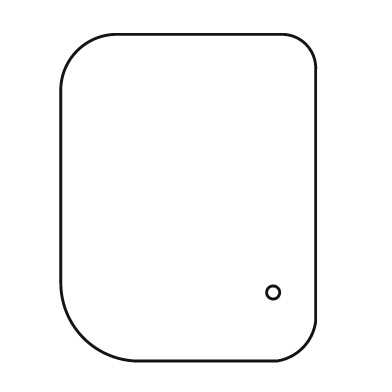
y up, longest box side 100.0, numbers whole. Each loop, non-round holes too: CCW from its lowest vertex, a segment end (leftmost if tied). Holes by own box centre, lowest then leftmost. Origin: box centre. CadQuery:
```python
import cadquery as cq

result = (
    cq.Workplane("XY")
    .moveTo(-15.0, -50.0)
    .lineTo(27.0, -50.0)
    .threePointArc((35.0, -46.0), (39.0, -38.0))
    .lineTo(39.0, 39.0)
    .threePointArc((36.0, 47.0), (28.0, 50.0))
    .lineTo(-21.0, 50.0)
    .threePointArc((-34.0, 45.0), (-39.0, 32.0))
    .lineTo(-39.0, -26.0)
    .threePointArc((-32.0, -43.0), (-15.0, -50.0))
    .close()
    .moveTo(26.0, -29.0)
    .circle(2.0)
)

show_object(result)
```